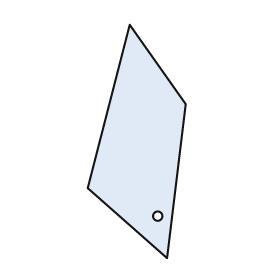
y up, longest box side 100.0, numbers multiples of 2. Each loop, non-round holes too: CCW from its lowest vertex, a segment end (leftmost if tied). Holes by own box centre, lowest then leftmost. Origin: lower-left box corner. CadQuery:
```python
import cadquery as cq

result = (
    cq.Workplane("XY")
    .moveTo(34.0, 0.0)
    .lineTo(42.0, 66.0)
    .lineTo(18.0, 100.0)
    .lineTo(0.0, 30.0)
    .close()
    .moveTo(30.0, 18.0)
    .circle(2.0)
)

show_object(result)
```